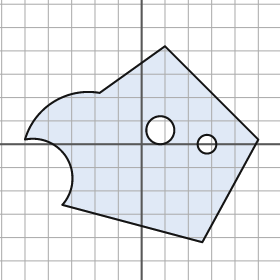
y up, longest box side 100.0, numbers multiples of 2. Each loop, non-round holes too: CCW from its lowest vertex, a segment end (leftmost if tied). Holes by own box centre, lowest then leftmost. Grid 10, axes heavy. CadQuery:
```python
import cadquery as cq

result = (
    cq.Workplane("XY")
    .moveTo(26.0, -42.0)
    .lineTo(50.0, 2.0)
    .lineTo(10.0, 42.0)
    .lineTo(-18.0, 22.0)
    .threePointArc((-38.0, 18.0), (-50.0, 2.0))
    .threePointArc((-32.0, -6.0), (-34.0, -26.0))
    .close()
    .moveTo(28.0, 0.0)
    .circle(4.0)
    .moveTo(8.0, 6.0)
    .circle(6.0)
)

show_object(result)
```